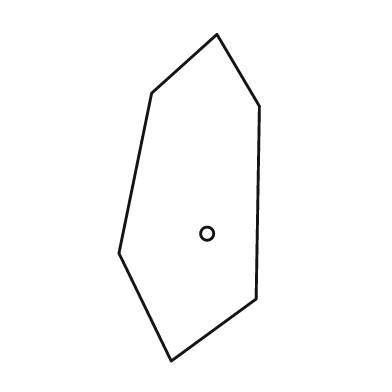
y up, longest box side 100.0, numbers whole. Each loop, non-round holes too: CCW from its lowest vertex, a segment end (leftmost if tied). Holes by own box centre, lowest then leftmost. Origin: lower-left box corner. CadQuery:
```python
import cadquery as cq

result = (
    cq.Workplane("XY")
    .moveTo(16.0, 0.0)
    .lineTo(42.0, 19.0)
    .lineTo(43.0, 78.0)
    .lineTo(30.0, 100.0)
    .lineTo(10.0, 82.0)
    .lineTo(0.0, 33.0)
    .close()
    .moveTo(27.0, 39.0)
    .circle(2.0)
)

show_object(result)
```